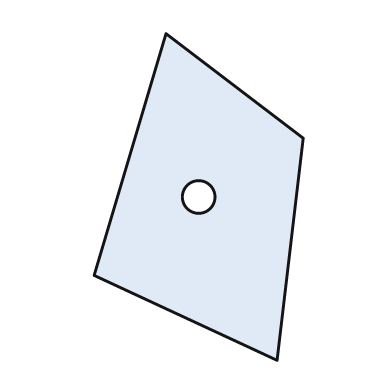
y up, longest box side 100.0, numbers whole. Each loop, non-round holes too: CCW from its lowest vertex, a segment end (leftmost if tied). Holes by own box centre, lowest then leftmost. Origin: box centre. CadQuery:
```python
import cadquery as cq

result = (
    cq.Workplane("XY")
    .moveTo(24.0, -50.0)
    .lineTo(32.0, 18.0)
    .lineTo(-10.0, 50.0)
    .lineTo(-32.0, -24.0)
    .close()
    .moveTo(0.0, 0.0)
    .circle(5.0)
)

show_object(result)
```